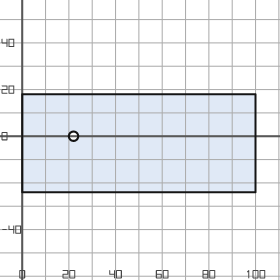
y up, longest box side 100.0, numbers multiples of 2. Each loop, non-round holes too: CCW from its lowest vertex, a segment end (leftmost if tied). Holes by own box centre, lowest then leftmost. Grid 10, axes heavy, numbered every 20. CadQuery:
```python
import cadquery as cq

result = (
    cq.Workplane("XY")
    .moveTo(0.0, -24.0)
    .lineTo(100.0, -24.0)
    .lineTo(100.0, 18.0)
    .lineTo(0.0, 18.0)
    .close()
    .moveTo(22.0, 0.0)
    .circle(2.0)
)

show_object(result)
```